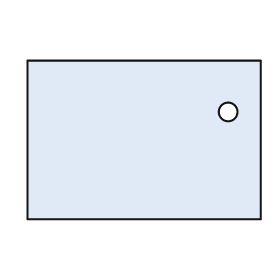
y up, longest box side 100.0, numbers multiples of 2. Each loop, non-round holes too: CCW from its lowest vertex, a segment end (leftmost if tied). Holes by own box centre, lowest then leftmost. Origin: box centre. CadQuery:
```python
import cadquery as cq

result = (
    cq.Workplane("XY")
    .moveTo(-50.0, -34.0)
    .lineTo(50.0, -34.0)
    .lineTo(50.0, 34.0)
    .lineTo(-50.0, 34.0)
    .close()
    .moveTo(36.0, 12.0)
    .circle(4.0)
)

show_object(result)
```